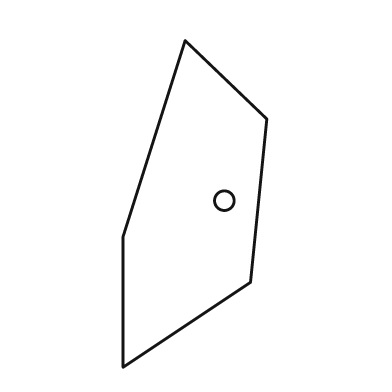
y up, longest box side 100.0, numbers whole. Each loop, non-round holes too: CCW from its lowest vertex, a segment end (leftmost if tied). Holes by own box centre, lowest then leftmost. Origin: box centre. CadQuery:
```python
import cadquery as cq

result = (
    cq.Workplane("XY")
    .moveTo(-22.0, -50.0)
    .lineTo(17.0, -24.0)
    .lineTo(22.0, 26.0)
    .lineTo(-3.0, 50.0)
    .lineTo(-22.0, -10.0)
    .close()
    .moveTo(9.0, 1.0)
    .circle(3.0)
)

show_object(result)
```